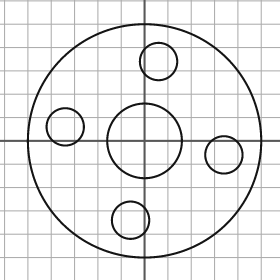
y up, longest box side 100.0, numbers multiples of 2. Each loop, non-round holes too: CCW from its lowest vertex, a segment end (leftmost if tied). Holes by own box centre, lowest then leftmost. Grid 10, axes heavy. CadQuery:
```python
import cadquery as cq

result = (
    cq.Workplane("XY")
    .moveTo(0.0, 0.0)
    .circle(50.0)
    .moveTo(-6.0, -34.0)
    .circle(8.0)
    .moveTo(34.0, -6.0)
    .circle(8.0)
    .moveTo(0.0, 0.0)
    .circle(16.0)
    .moveTo(-34.0, 6.0)
    .circle(8.0)
    .moveTo(6.0, 34.0)
    .circle(8.0)
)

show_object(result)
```